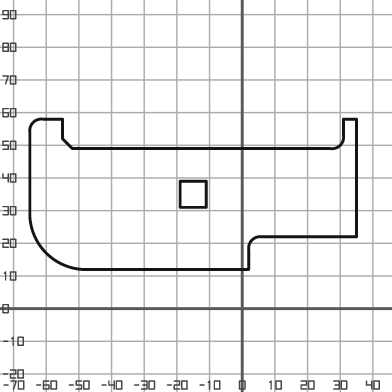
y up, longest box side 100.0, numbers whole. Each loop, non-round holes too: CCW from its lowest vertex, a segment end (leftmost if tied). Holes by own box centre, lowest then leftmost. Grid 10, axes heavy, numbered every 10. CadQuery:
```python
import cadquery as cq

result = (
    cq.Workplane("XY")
    .moveTo(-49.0, 12.0)
    .lineTo(2.0, 12.0)
    .lineTo(2.0, 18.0)
    .threePointArc((3.0, 21.0), (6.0, 22.0))
    .lineTo(35.0, 22.0)
    .lineTo(35.0, 58.0)
    .lineTo(31.0, 58.0)
    .lineTo(31.0, 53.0)
    .threePointArc((30.0, 50.0), (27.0, 49.0))
    .lineTo(-52.0, 49.0)
    .lineTo(-55.0, 52.0)
    .lineTo(-55.0, 58.0)
    .lineTo(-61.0, 58.0)
    .threePointArc((-64.0, 57.0), (-65.0, 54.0))
    .lineTo(-65.0, 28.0)
    .threePointArc((-60.0, 17.0), (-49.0, 12.0))
    .close()
    .moveTo(-19.0, 31.0)
    .lineTo(-11.0, 31.0)
    .lineTo(-11.0, 39.0)
    .lineTo(-19.0, 39.0)
    .close()
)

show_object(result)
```